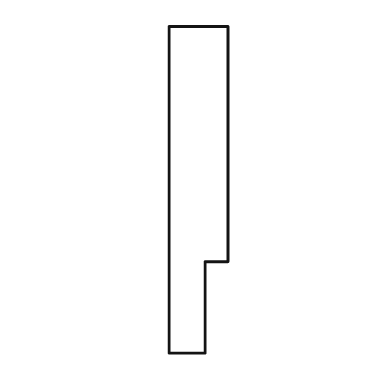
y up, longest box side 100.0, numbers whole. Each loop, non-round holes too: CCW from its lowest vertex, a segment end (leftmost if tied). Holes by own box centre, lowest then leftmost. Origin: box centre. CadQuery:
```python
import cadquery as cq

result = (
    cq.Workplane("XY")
    .moveTo(-9.0, -50.0)
    .lineTo(2.0, -50.0)
    .lineTo(2.0, -22.0)
    .lineTo(9.0, -22.0)
    .lineTo(9.0, 50.0)
    .lineTo(-9.0, 50.0)
    .close()
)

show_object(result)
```